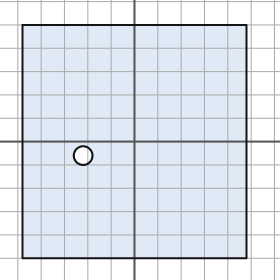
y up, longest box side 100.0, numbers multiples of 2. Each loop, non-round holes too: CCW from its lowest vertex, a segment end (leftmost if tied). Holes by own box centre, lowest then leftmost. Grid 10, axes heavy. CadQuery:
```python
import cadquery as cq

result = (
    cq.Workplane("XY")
    .moveTo(-48.0, -50.0)
    .lineTo(48.0, -50.0)
    .lineTo(48.0, 50.0)
    .lineTo(-48.0, 50.0)
    .close()
    .moveTo(-22.0, -6.0)
    .circle(4.0)
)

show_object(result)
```